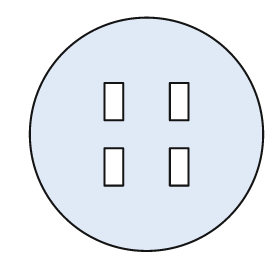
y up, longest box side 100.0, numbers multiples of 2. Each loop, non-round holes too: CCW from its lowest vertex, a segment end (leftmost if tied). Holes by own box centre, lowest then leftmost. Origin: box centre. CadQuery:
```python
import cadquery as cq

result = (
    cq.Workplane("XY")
    .moveTo(0.0, 0.0)
    .circle(50.0)
    .moveTo(-18.0, -22.0)
    .lineTo(-10.0, -22.0)
    .lineTo(-10.0, -6.0)
    .lineTo(-18.0, -6.0)
    .close()
    .moveTo(10.0, -22.0)
    .lineTo(18.0, -22.0)
    .lineTo(18.0, -6.0)
    .lineTo(10.0, -6.0)
    .close()
    .moveTo(-18.0, 6.0)
    .lineTo(-10.0, 6.0)
    .lineTo(-10.0, 22.0)
    .lineTo(-18.0, 22.0)
    .close()
    .moveTo(10.0, 6.0)
    .lineTo(18.0, 6.0)
    .lineTo(18.0, 22.0)
    .lineTo(10.0, 22.0)
    .close()
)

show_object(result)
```